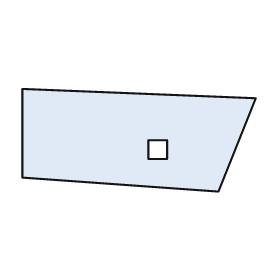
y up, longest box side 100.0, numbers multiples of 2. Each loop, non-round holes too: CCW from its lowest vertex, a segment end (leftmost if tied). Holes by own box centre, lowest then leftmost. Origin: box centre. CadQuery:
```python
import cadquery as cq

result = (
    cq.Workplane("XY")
    .moveTo(34.0, -22.0)
    .lineTo(50.0, 18.0)
    .lineTo(-50.0, 22.0)
    .lineTo(-50.0, -16.0)
    .close()
    .moveTo(4.0, -8.0)
    .lineTo(12.0, -8.0)
    .lineTo(12.0, 0.0)
    .lineTo(4.0, 0.0)
    .close()
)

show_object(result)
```